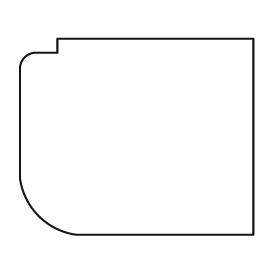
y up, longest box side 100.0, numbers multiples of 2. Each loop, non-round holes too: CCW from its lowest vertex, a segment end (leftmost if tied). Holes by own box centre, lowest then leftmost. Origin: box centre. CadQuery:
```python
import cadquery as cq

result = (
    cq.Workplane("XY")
    .moveTo(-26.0, -42.0)
    .lineTo(50.0, -42.0)
    .lineTo(50.0, 42.0)
    .lineTo(-34.0, 42.0)
    .lineTo(-34.0, 36.0)
    .lineTo(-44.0, 36.0)
    .threePointArc((-48.0, 34.0), (-50.0, 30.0))
    .lineTo(-50.0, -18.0)
    .threePointArc((-42.0, -34.0), (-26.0, -42.0))
    .close()
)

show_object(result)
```